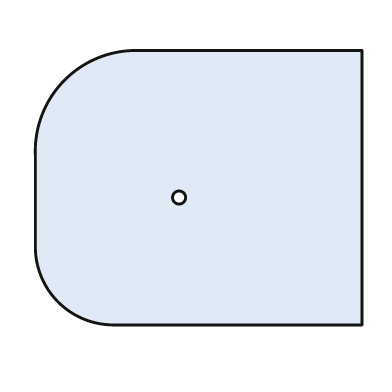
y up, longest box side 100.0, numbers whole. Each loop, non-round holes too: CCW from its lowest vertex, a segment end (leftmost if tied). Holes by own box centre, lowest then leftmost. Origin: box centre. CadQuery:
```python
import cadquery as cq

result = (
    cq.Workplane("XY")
    .moveTo(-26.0, -42.0)
    .lineTo(50.0, -42.0)
    .lineTo(50.0, 42.0)
    .lineTo(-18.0, 42.0)
    .threePointArc((-41.0, 33.0), (-50.0, 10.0))
    .lineTo(-50.0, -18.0)
    .threePointArc((-43.0, -35.0), (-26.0, -42.0))
    .close()
    .moveTo(-6.0, -3.0)
    .circle(2.0)
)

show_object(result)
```